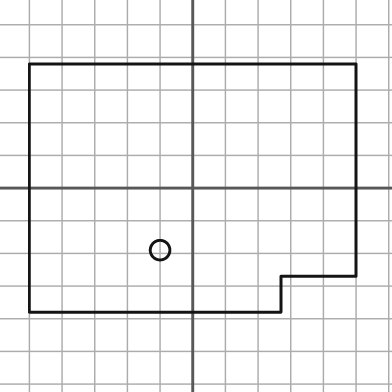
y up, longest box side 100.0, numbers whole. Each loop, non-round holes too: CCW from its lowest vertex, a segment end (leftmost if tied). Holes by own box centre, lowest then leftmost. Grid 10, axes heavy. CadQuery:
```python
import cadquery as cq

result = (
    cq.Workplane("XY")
    .moveTo(-50.0, -38.0)
    .lineTo(27.0, -38.0)
    .lineTo(27.0, -27.0)
    .lineTo(50.0, -27.0)
    .lineTo(50.0, 38.0)
    .lineTo(-50.0, 38.0)
    .close()
    .moveTo(-10.0, -19.0)
    .circle(3.0)
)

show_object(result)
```